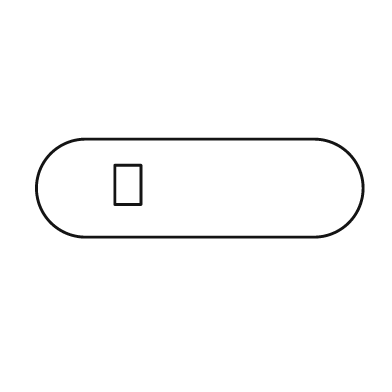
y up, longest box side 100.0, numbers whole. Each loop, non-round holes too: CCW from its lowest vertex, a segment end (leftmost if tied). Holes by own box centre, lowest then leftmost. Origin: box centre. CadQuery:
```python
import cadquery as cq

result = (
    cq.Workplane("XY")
    .moveTo(-35.0, -15.0)
    .lineTo(35.0, -15.0)
    .threePointArc((50.0, 0.0), (35.0, 15.0))
    .lineTo(-35.0, 15.0)
    .threePointArc((-50.0, 0.0), (-35.0, -15.0))
    .close()
    .moveTo(-26.0, -5.0)
    .lineTo(-18.0, -5.0)
    .lineTo(-18.0, 7.0)
    .lineTo(-26.0, 7.0)
    .close()
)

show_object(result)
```